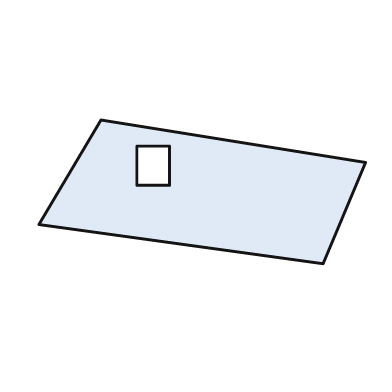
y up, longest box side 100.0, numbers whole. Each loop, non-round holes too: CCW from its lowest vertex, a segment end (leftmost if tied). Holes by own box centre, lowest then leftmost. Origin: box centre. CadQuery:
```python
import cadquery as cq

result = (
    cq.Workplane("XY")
    .moveTo(37.0, -22.0)
    .lineTo(50.0, 9.0)
    .lineTo(-31.0, 22.0)
    .lineTo(-50.0, -10.0)
    .close()
    .moveTo(-20.0, 2.0)
    .lineTo(-10.0, 2.0)
    .lineTo(-10.0, 14.0)
    .lineTo(-20.0, 14.0)
    .close()
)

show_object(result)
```